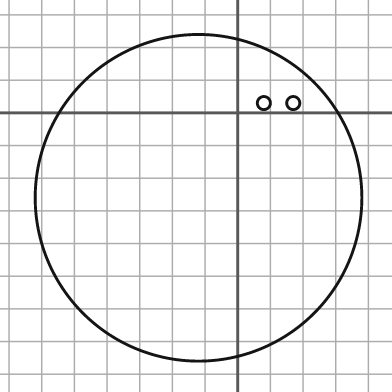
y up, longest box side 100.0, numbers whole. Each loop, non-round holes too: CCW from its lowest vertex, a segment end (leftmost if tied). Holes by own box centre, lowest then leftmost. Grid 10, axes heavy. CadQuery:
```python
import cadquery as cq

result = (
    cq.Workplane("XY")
    .moveTo(-12.0, -26.0)
    .circle(50.0)
    .moveTo(8.0, 3.0)
    .circle(2.0)
    .moveTo(17.0, 3.0)
    .circle(2.0)
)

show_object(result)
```